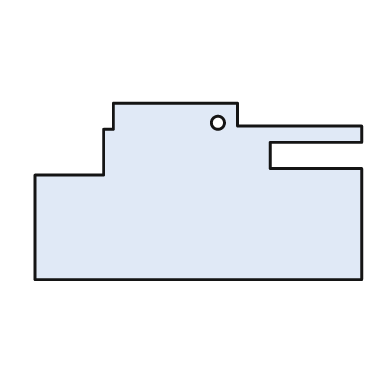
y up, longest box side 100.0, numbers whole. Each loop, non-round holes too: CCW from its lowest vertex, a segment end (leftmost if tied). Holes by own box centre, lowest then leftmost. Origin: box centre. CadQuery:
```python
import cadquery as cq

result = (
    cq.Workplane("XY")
    .moveTo(-50.0, -27.0)
    .lineTo(50.0, -27.0)
    .lineTo(50.0, 7.0)
    .lineTo(22.0, 7.0)
    .lineTo(22.0, 15.0)
    .lineTo(50.0, 15.0)
    .lineTo(50.0, 20.0)
    .lineTo(12.0, 20.0)
    .lineTo(12.0, 27.0)
    .lineTo(-26.0, 27.0)
    .lineTo(-26.0, 19.0)
    .lineTo(-29.0, 19.0)
    .lineTo(-29.0, 5.0)
    .lineTo(-50.0, 5.0)
    .close()
    .moveTo(6.0, 21.0)
    .circle(2.0)
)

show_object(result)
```